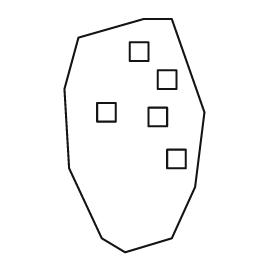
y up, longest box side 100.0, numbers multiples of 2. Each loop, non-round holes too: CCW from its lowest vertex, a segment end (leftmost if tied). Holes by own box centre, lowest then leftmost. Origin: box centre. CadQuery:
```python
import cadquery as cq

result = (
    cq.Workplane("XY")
    .moveTo(-4.0, -50.0)
    .lineTo(16.0, -44.0)
    .lineTo(26.0, -22.0)
    .lineTo(30.0, 10.0)
    .lineTo(16.0, 50.0)
    .lineTo(4.0, 50.0)
    .lineTo(-24.0, 42.0)
    .lineTo(-30.0, 20.0)
    .lineTo(-28.0, -14.0)
    .lineTo(-14.0, -44.0)
    .close()
    .moveTo(14.0, -14.0)
    .lineTo(22.0, -14.0)
    .lineTo(22.0, -6.0)
    .lineTo(14.0, -6.0)
    .close()
    .moveTo(6.0, 4.0)
    .lineTo(14.0, 4.0)
    .lineTo(14.0, 12.0)
    .lineTo(6.0, 12.0)
    .close()
    .moveTo(-16.0, 6.0)
    .lineTo(-8.0, 6.0)
    .lineTo(-8.0, 14.0)
    .lineTo(-16.0, 14.0)
    .close()
    .moveTo(10.0, 20.0)
    .lineTo(18.0, 20.0)
    .lineTo(18.0, 28.0)
    .lineTo(10.0, 28.0)
    .close()
    .moveTo(-2.0, 32.0)
    .lineTo(6.0, 32.0)
    .lineTo(6.0, 40.0)
    .lineTo(-2.0, 40.0)
    .close()
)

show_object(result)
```